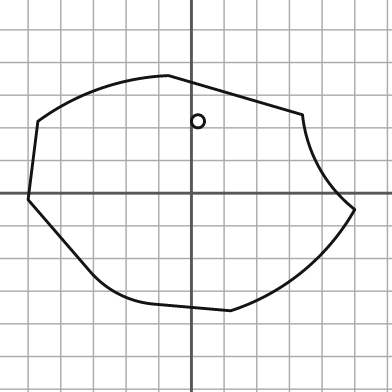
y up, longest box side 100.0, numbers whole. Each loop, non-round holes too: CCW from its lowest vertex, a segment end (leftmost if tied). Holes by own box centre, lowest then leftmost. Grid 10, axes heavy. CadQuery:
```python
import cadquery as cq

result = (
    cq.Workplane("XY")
    .moveTo(12.0, -36.0)
    .threePointArc((34.0, -24.0), (50.0, -5.0))
    .threePointArc((39.0, 8.0), (34.0, 24.0))
    .lineTo(-7.0, 36.0)
    .threePointArc((-28.0, 32.0), (-47.0, 22.0))
    .lineTo(-50.0, -2.0)
    .lineTo(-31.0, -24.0)
    .threePointArc((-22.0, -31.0), (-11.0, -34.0))
    .close()
    .moveTo(2.0, 22.0)
    .circle(2.0)
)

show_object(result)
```